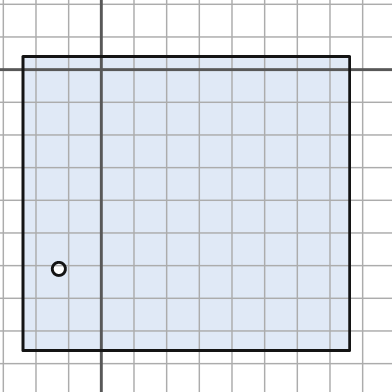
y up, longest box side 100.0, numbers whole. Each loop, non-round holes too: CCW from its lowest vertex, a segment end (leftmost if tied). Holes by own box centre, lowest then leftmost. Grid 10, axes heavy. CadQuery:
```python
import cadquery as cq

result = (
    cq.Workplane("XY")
    .moveTo(-24.0, -86.0)
    .lineTo(76.0, -86.0)
    .lineTo(76.0, 4.0)
    .lineTo(-24.0, 4.0)
    .close()
    .moveTo(-13.0, -61.0)
    .circle(2.0)
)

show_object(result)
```